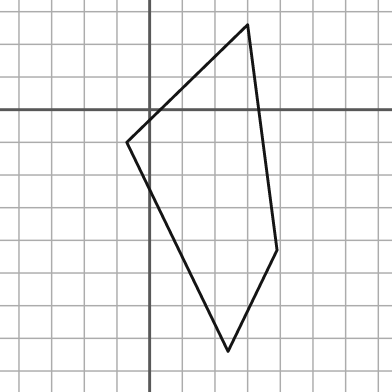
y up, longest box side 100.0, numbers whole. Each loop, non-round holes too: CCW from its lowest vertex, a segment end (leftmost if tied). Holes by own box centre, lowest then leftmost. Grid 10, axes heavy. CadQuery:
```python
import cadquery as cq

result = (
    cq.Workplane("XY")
    .moveTo(24.0, -74.0)
    .lineTo(39.0, -43.0)
    .lineTo(30.0, 26.0)
    .lineTo(-7.0, -10.0)
    .close()
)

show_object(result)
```